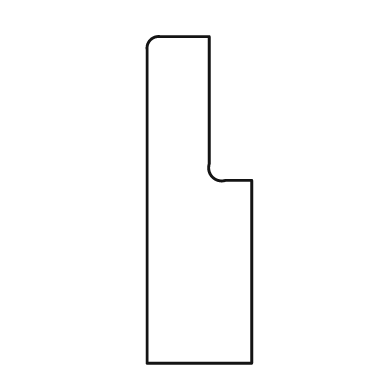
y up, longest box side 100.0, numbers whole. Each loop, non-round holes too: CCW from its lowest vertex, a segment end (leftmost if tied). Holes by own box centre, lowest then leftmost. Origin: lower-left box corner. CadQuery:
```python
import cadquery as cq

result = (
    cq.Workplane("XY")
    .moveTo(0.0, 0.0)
    .lineTo(32.0, 0.0)
    .lineTo(32.0, 56.0)
    .lineTo(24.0, 56.0)
    .threePointArc((20.0, 57.0), (19.0, 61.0))
    .lineTo(19.0, 100.0)
    .lineTo(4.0, 100.0)
    .threePointArc((1.0, 99.0), (0.0, 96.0))
    .close()
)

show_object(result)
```